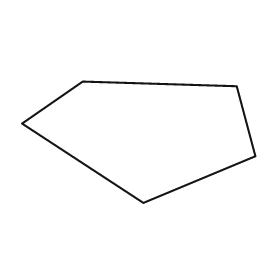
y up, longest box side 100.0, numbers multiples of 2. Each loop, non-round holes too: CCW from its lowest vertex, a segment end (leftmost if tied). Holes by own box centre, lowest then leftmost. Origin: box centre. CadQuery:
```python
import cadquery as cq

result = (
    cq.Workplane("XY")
    .moveTo(2.0, -26.0)
    .lineTo(50.0, -6.0)
    .lineTo(42.0, 24.0)
    .lineTo(-24.0, 26.0)
    .lineTo(-50.0, 8.0)
    .close()
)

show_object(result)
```